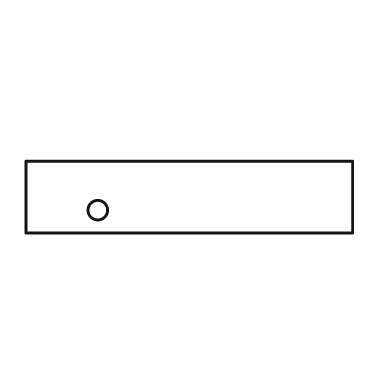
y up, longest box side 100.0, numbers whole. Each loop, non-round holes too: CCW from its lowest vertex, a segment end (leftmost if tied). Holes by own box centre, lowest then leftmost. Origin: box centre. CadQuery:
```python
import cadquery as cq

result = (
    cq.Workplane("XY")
    .moveTo(-50.0, -11.0)
    .lineTo(50.0, -11.0)
    .lineTo(50.0, 11.0)
    .lineTo(-50.0, 11.0)
    .close()
    .moveTo(-28.0, -4.0)
    .circle(3.0)
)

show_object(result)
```